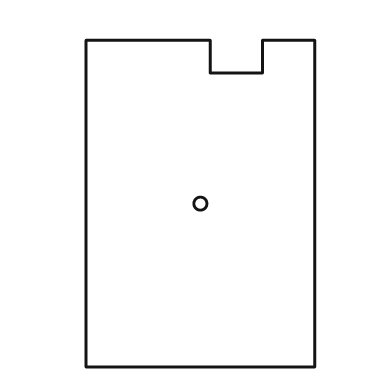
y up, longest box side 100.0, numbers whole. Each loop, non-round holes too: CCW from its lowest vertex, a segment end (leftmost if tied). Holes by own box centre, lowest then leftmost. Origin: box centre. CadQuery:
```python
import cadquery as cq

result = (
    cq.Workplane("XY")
    .moveTo(-35.0, -50.0)
    .lineTo(35.0, -50.0)
    .lineTo(35.0, 50.0)
    .lineTo(19.0, 50.0)
    .lineTo(19.0, 40.0)
    .lineTo(3.0, 40.0)
    .lineTo(3.0, 50.0)
    .lineTo(-35.0, 50.0)
    .close()
    .moveTo(0.0, 0.0)
    .circle(2.0)
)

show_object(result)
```